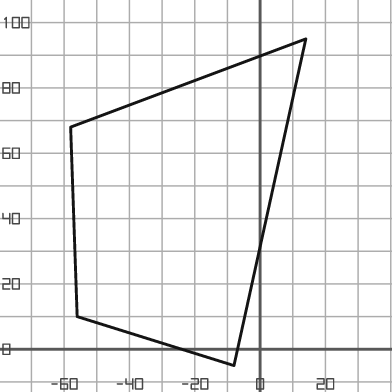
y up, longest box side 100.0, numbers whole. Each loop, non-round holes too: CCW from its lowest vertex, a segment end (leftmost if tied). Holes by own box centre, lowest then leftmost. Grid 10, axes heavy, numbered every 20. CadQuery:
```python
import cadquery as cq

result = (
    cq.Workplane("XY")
    .moveTo(-8.0, -5.0)
    .lineTo(14.0, 95.0)
    .lineTo(-58.0, 68.0)
    .lineTo(-56.0, 10.0)
    .close()
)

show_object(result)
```